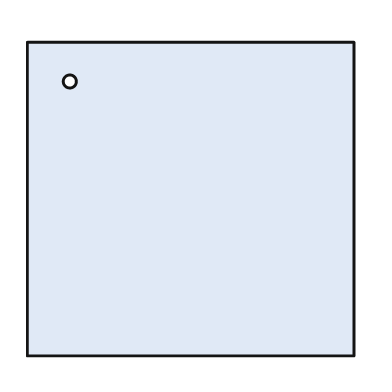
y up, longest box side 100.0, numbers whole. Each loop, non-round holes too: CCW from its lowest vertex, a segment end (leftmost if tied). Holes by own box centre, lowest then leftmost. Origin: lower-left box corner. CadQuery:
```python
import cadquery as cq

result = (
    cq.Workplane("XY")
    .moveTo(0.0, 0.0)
    .lineTo(100.0, 0.0)
    .lineTo(100.0, 96.0)
    .lineTo(0.0, 96.0)
    .close()
    .moveTo(13.0, 84.0)
    .circle(2.0)
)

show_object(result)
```